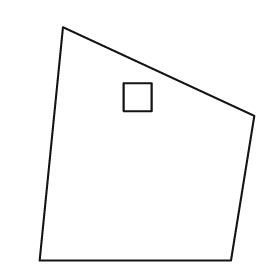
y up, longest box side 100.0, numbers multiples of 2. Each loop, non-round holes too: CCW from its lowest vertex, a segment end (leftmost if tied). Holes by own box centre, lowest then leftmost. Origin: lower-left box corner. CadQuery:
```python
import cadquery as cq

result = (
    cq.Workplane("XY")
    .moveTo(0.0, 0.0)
    .lineTo(82.0, 0.0)
    .lineTo(92.0, 62.0)
    .lineTo(10.0, 100.0)
    .close()
    .moveTo(36.0, 64.0)
    .lineTo(48.0, 64.0)
    .lineTo(48.0, 76.0)
    .lineTo(36.0, 76.0)
    .close()
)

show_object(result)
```